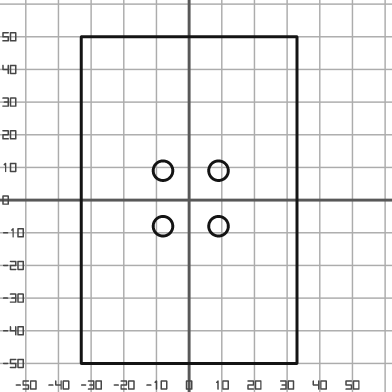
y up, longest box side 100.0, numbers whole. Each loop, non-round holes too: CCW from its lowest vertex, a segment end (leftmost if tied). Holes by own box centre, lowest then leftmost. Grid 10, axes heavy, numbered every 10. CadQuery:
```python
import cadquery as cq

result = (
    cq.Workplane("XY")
    .moveTo(-33.0, -50.0)
    .lineTo(33.0, -50.0)
    .lineTo(33.0, 50.0)
    .lineTo(-33.0, 50.0)
    .close()
    .moveTo(-8.0, -8.0)
    .circle(3.0)
    .moveTo(9.0, -8.0)
    .circle(3.0)
    .moveTo(-8.0, 9.0)
    .circle(3.0)
    .moveTo(9.0, 9.0)
    .circle(3.0)
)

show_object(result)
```